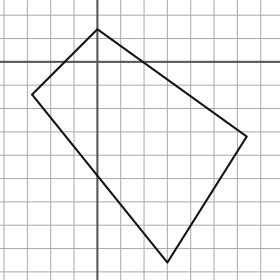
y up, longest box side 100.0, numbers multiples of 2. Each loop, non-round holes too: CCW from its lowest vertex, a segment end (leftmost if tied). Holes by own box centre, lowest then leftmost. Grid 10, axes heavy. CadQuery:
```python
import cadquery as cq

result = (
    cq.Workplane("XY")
    .moveTo(30.0, -86.0)
    .lineTo(64.0, -32.0)
    .lineTo(0.0, 14.0)
    .lineTo(-28.0, -14.0)
    .close()
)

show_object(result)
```